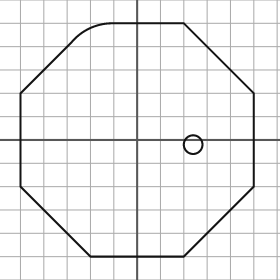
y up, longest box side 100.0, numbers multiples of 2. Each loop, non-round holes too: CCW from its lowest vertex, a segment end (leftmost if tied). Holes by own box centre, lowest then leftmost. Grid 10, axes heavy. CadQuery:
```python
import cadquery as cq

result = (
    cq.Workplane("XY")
    .moveTo(-20.0, -50.0)
    .lineTo(20.0, -50.0)
    .lineTo(50.0, -20.0)
    .lineTo(50.0, 20.0)
    .lineTo(20.0, 50.0)
    .lineTo(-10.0, 50.0)
    .threePointArc((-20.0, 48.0), (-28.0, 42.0))
    .lineTo(-50.0, 20.0)
    .lineTo(-50.0, -20.0)
    .close()
    .moveTo(24.0, -2.0)
    .circle(4.0)
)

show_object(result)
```